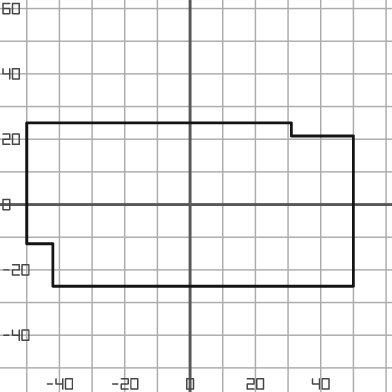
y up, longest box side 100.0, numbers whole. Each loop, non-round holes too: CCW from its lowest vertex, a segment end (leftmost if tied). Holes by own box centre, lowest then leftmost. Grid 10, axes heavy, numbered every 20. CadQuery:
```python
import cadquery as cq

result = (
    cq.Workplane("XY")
    .moveTo(-42.0, -25.0)
    .lineTo(50.0, -25.0)
    .lineTo(50.0, 21.0)
    .lineTo(31.0, 21.0)
    .lineTo(31.0, 25.0)
    .lineTo(-50.0, 25.0)
    .lineTo(-50.0, -12.0)
    .lineTo(-42.0, -12.0)
    .close()
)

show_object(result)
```